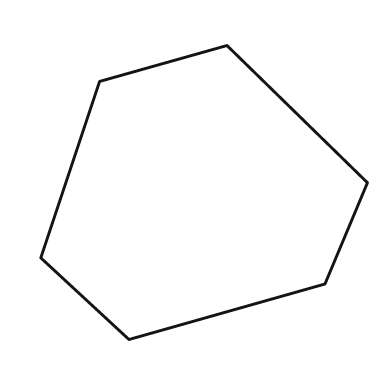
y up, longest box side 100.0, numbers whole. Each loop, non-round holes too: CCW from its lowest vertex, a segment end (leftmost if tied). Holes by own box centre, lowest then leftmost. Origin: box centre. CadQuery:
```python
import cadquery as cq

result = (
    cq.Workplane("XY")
    .moveTo(-23.0, -45.0)
    .lineTo(37.0, -28.0)
    .lineTo(50.0, 3.0)
    .lineTo(7.0, 45.0)
    .lineTo(-32.0, 34.0)
    .lineTo(-50.0, -20.0)
    .close()
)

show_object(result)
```